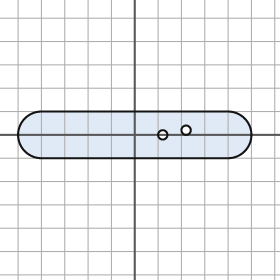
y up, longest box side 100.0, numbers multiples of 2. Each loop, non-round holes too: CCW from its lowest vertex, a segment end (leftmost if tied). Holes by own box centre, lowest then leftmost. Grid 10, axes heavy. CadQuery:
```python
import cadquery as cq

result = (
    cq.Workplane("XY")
    .moveTo(-40.0, -10.0)
    .lineTo(40.0, -10.0)
    .threePointArc((50.0, 0.0), (40.0, 10.0))
    .lineTo(-40.0, 10.0)
    .threePointArc((-50.0, 0.0), (-40.0, -10.0))
    .close()
    .moveTo(12.0, 0.0)
    .circle(2.0)
    .moveTo(22.0, 2.0)
    .circle(2.0)
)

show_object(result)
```